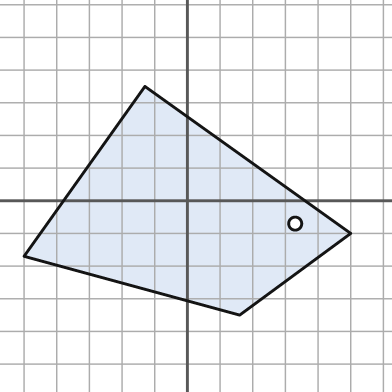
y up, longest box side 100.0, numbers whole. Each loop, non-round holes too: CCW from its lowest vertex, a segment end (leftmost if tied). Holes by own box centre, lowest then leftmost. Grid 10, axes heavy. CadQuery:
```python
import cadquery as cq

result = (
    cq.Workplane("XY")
    .moveTo(16.0, -35.0)
    .lineTo(50.0, -10.0)
    .lineTo(-13.0, 35.0)
    .lineTo(-50.0, -17.0)
    .close()
    .moveTo(33.0, -7.0)
    .circle(2.0)
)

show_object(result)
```